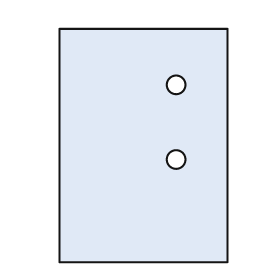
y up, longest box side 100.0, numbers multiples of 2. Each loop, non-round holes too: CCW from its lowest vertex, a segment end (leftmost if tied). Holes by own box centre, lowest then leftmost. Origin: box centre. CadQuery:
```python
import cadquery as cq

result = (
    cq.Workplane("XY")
    .moveTo(-36.0, -50.0)
    .lineTo(36.0, -50.0)
    .lineTo(36.0, 50.0)
    .lineTo(-36.0, 50.0)
    .close()
    .moveTo(14.0, -6.0)
    .circle(4.0)
    .moveTo(14.0, 26.0)
    .circle(4.0)
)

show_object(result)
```